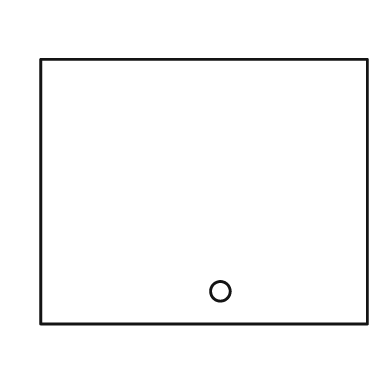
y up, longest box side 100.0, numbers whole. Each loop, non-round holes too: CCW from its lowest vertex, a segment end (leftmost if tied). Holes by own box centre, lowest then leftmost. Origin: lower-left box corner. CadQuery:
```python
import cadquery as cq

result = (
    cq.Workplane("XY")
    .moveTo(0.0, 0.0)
    .lineTo(100.0, 0.0)
    .lineTo(100.0, 81.0)
    .lineTo(0.0, 81.0)
    .close()
    .moveTo(55.0, 10.0)
    .circle(3.0)
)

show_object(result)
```